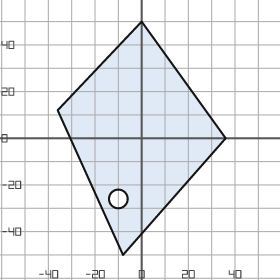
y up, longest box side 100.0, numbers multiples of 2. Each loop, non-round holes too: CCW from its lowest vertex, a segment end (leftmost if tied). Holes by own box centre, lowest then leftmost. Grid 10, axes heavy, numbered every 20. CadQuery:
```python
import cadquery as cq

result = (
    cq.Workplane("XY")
    .moveTo(-8.0, -50.0)
    .lineTo(36.0, 0.0)
    .lineTo(0.0, 50.0)
    .lineTo(-36.0, 12.0)
    .close()
    .moveTo(-10.0, -26.0)
    .circle(4.0)
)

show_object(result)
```